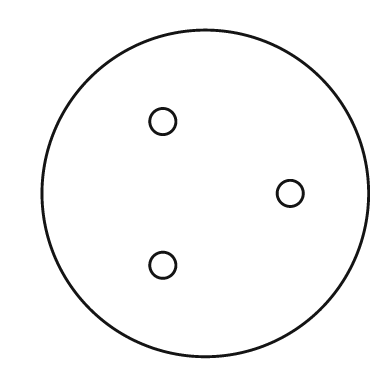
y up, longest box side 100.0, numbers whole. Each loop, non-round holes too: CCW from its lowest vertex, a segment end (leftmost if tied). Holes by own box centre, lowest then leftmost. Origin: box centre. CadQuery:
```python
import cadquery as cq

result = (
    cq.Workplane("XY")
    .moveTo(0.0, 0.0)
    .circle(50.0)
    .moveTo(-13.0, -22.0)
    .circle(4.0)
    .moveTo(26.0, 0.0)
    .circle(4.0)
    .moveTo(-13.0, 22.0)
    .circle(4.0)
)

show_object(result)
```